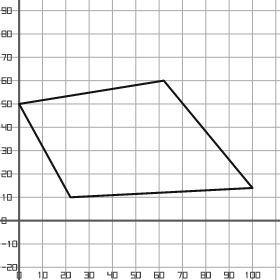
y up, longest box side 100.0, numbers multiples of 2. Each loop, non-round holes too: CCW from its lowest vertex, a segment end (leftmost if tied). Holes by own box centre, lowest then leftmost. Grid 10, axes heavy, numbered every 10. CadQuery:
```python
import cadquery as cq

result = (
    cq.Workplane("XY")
    .moveTo(22.0, 10.0)
    .lineTo(100.0, 14.0)
    .lineTo(62.0, 60.0)
    .lineTo(0.0, 50.0)
    .close()
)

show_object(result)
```